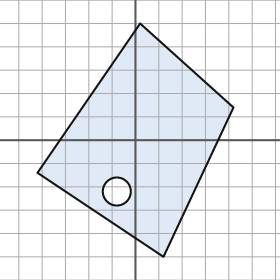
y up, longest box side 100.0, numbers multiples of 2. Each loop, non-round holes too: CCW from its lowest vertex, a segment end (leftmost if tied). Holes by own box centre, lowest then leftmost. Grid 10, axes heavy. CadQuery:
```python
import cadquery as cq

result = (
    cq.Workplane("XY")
    .moveTo(12.0, -50.0)
    .lineTo(42.0, 14.0)
    .lineTo(2.0, 50.0)
    .lineTo(-42.0, -14.0)
    .close()
    .moveTo(-8.0, -22.0)
    .circle(6.0)
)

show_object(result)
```